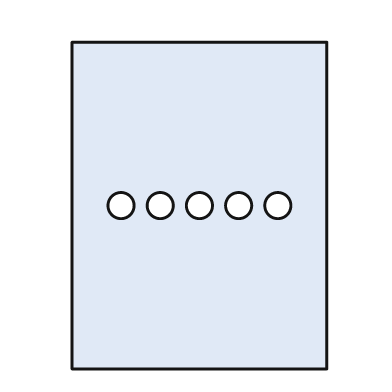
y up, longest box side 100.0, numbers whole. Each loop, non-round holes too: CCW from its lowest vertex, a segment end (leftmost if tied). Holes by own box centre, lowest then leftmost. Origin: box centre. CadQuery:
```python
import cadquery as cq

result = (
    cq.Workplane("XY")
    .moveTo(-39.0, -50.0)
    .lineTo(39.0, -50.0)
    .lineTo(39.0, 50.0)
    .lineTo(-39.0, 50.0)
    .close()
    .moveTo(-24.0, 0.0)
    .circle(4.0)
    .moveTo(-12.0, 0.0)
    .circle(4.0)
    .moveTo(0.0, 0.0)
    .circle(4.0)
    .moveTo(12.0, 0.0)
    .circle(4.0)
    .moveTo(24.0, 0.0)
    .circle(4.0)
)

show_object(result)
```